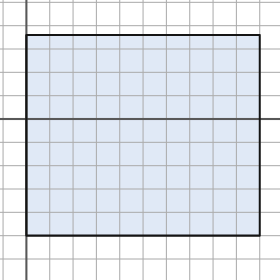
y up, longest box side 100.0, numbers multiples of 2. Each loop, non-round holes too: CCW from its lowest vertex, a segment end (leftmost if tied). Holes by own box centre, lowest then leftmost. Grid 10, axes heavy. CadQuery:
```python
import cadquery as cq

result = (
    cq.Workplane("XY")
    .moveTo(0.0, -50.0)
    .lineTo(100.0, -50.0)
    .lineTo(100.0, 36.0)
    .lineTo(0.0, 36.0)
    .close()
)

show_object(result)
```